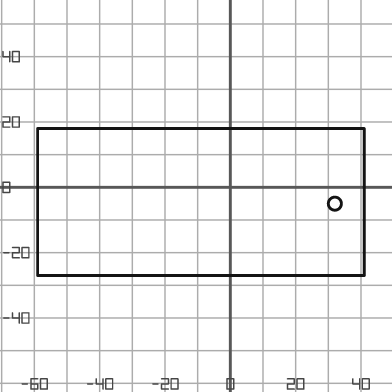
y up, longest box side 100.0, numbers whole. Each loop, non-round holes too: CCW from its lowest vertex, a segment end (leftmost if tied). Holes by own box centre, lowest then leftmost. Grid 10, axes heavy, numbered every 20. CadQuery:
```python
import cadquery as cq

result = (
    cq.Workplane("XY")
    .moveTo(-59.0, -27.0)
    .lineTo(41.0, -27.0)
    .lineTo(41.0, 18.0)
    .lineTo(-59.0, 18.0)
    .close()
    .moveTo(32.0, -5.0)
    .circle(2.0)
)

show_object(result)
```